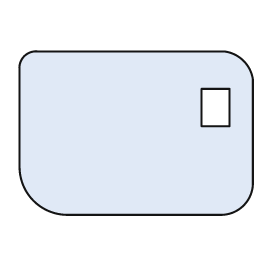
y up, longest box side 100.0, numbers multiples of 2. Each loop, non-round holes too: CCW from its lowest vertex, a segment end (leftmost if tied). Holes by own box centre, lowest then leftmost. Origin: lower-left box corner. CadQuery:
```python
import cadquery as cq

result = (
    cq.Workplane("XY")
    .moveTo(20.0, 0.0)
    .lineTo(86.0, 0.0)
    .threePointArc((96.0, 4.0), (100.0, 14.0))
    .lineTo(100.0, 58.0)
    .threePointArc((96.0, 66.0), (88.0, 70.0))
    .lineTo(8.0, 70.0)
    .threePointArc((2.0, 68.0), (0.0, 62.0))
    .lineTo(0.0, 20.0)
    .threePointArc((6.0, 6.0), (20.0, 0.0))
    .close()
    .moveTo(78.0, 38.0)
    .lineTo(90.0, 38.0)
    .lineTo(90.0, 54.0)
    .lineTo(78.0, 54.0)
    .close()
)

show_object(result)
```